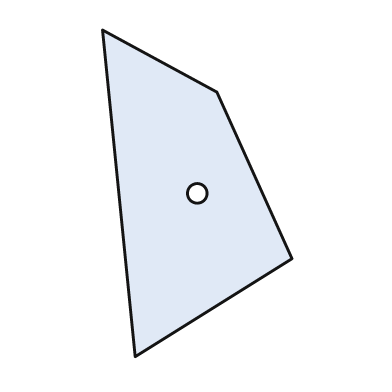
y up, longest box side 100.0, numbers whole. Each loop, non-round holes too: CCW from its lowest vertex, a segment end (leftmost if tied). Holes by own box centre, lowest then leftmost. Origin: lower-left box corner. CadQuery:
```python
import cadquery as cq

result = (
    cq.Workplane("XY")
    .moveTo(10.0, 0.0)
    .lineTo(58.0, 30.0)
    .lineTo(35.0, 81.0)
    .lineTo(0.0, 100.0)
    .close()
    .moveTo(29.0, 50.0)
    .circle(3.0)
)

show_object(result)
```